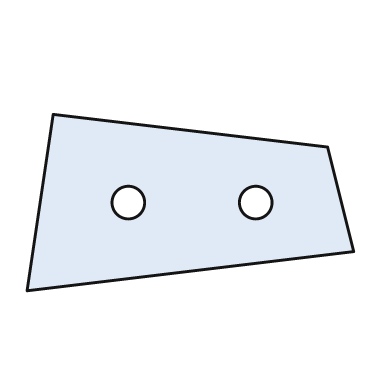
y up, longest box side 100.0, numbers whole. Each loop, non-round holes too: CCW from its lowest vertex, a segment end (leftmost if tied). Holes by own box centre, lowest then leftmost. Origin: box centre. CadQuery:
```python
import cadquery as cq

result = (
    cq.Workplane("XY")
    .moveTo(-50.0, -27.0)
    .lineTo(50.0, -15.0)
    .lineTo(42.0, 17.0)
    .lineTo(-42.0, 27.0)
    .close()
    .moveTo(-19.0, 0.0)
    .circle(5.0)
    .moveTo(20.0, 0.0)
    .circle(5.0)
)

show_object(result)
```